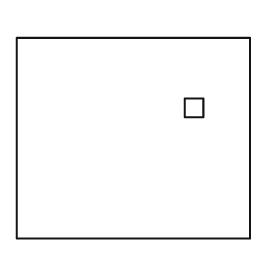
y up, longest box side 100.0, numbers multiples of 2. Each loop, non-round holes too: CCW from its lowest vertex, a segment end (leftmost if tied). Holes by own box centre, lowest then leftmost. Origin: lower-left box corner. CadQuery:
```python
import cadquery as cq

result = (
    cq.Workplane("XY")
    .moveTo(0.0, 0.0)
    .lineTo(100.0, 0.0)
    .lineTo(100.0, 86.0)
    .lineTo(0.0, 86.0)
    .close()
    .moveTo(72.0, 52.0)
    .lineTo(80.0, 52.0)
    .lineTo(80.0, 60.0)
    .lineTo(72.0, 60.0)
    .close()
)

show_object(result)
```